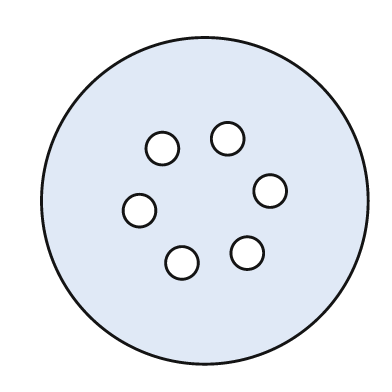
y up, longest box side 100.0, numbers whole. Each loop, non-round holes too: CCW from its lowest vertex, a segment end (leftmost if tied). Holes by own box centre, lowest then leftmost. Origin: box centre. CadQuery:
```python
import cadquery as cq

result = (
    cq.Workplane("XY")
    .moveTo(0.0, 0.0)
    .circle(50.0)
    .moveTo(-7.0, -19.0)
    .circle(5.0)
    .moveTo(13.0, -16.0)
    .circle(5.0)
    .moveTo(-20.0, -3.0)
    .circle(5.0)
    .moveTo(20.0, 3.0)
    .circle(5.0)
    .moveTo(-13.0, 16.0)
    .circle(5.0)
    .moveTo(7.0, 19.0)
    .circle(5.0)
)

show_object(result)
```